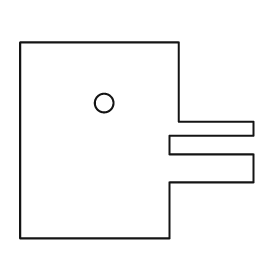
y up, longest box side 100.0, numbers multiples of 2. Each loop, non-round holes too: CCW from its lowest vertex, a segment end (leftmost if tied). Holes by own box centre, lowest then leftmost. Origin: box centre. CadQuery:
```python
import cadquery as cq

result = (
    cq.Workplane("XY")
    .moveTo(-50.0, -42.0)
    .lineTo(14.0, -42.0)
    .lineTo(14.0, -18.0)
    .lineTo(50.0, -18.0)
    .lineTo(50.0, -6.0)
    .lineTo(14.0, -6.0)
    .lineTo(14.0, 2.0)
    .lineTo(50.0, 2.0)
    .lineTo(50.0, 8.0)
    .lineTo(18.0, 8.0)
    .lineTo(18.0, 42.0)
    .lineTo(-50.0, 42.0)
    .close()
    .moveTo(-14.0, 16.0)
    .circle(4.0)
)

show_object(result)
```